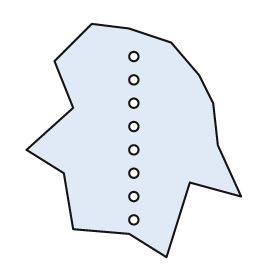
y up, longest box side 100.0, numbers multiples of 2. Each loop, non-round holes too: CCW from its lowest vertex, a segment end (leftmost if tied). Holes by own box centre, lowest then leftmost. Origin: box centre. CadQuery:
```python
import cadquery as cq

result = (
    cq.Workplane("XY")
    .moveTo(14.0, -50.0)
    .lineTo(24.0, -18.0)
    .lineTo(46.0, -24.0)
    .lineTo(36.0, -2.0)
    .lineTo(34.0, 16.0)
    .lineTo(28.0, 28.0)
    .lineTo(16.0, 42.0)
    .lineTo(-2.0, 48.0)
    .lineTo(-18.0, 50.0)
    .lineTo(-34.0, 34.0)
    .lineTo(-26.0, 14.0)
    .lineTo(-46.0, -4.0)
    .lineTo(-30.0, -14.0)
    .lineTo(-26.0, -38.0)
    .lineTo(-2.0, -40.0)
    .close()
    .moveTo(0.0, -34.0)
    .circle(2.0)
    .moveTo(0.0, -24.0)
    .circle(2.0)
    .moveTo(0.0, -14.0)
    .circle(2.0)
    .moveTo(0.0, -4.0)
    .circle(2.0)
    .moveTo(0.0, 6.0)
    .circle(2.0)
    .moveTo(0.0, 16.0)
    .circle(2.0)
    .moveTo(0.0, 26.0)
    .circle(2.0)
    .moveTo(0.0, 36.0)
    .circle(2.0)
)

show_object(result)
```